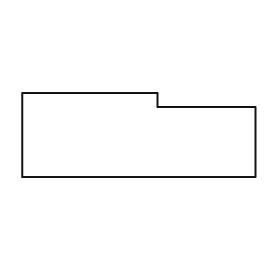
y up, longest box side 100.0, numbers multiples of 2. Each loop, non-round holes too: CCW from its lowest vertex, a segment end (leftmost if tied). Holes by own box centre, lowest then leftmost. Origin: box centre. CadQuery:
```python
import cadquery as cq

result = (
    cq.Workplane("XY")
    .moveTo(-50.0, -18.0)
    .lineTo(50.0, -18.0)
    .lineTo(50.0, 12.0)
    .lineTo(8.0, 12.0)
    .lineTo(8.0, 18.0)
    .lineTo(-50.0, 18.0)
    .close()
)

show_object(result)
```